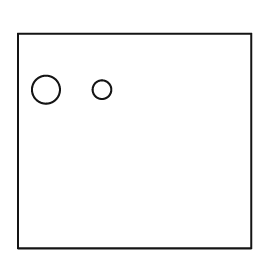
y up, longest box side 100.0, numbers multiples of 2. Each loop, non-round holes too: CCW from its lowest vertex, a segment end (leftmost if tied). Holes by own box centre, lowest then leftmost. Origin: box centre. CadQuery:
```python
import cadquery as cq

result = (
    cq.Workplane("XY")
    .moveTo(-50.0, -46.0)
    .lineTo(50.0, -46.0)
    .lineTo(50.0, 46.0)
    .lineTo(-50.0, 46.0)
    .close()
    .moveTo(-38.0, 22.0)
    .circle(6.0)
    .moveTo(-14.0, 22.0)
    .circle(4.0)
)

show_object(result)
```